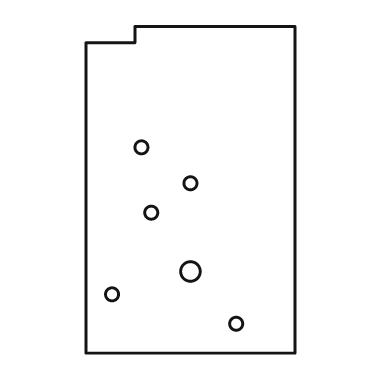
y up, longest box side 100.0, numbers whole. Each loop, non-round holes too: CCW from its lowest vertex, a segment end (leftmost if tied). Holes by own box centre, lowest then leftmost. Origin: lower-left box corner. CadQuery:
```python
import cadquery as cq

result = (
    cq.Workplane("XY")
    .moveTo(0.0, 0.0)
    .lineTo(64.0, 0.0)
    .lineTo(64.0, 100.0)
    .lineTo(15.0, 100.0)
    .lineTo(15.0, 95.0)
    .lineTo(0.0, 95.0)
    .close()
    .moveTo(46.0, 9.0)
    .circle(2.0)
    .moveTo(8.0, 18.0)
    .circle(2.0)
    .moveTo(32.0, 25.0)
    .circle(3.0)
    .moveTo(20.0, 43.0)
    .circle(2.0)
    .moveTo(32.0, 52.0)
    .circle(2.0)
    .moveTo(17.0, 63.0)
    .circle(2.0)
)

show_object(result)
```